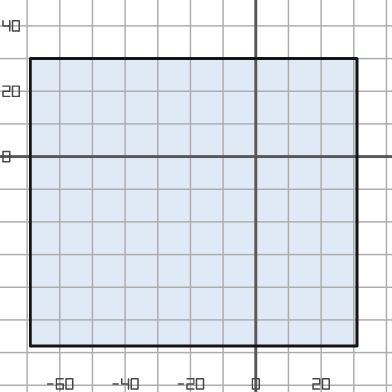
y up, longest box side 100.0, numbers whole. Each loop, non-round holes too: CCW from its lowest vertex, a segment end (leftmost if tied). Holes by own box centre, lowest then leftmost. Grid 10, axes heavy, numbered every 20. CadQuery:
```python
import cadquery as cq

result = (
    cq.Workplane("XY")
    .moveTo(-69.0, -58.0)
    .lineTo(31.0, -58.0)
    .lineTo(31.0, 30.0)
    .lineTo(-69.0, 30.0)
    .close()
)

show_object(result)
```